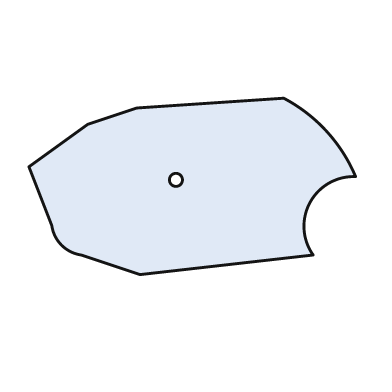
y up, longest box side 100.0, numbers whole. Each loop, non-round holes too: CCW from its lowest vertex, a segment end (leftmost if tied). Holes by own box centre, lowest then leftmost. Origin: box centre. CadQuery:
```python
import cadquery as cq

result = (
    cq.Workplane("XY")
    .moveTo(-16.0, -27.0)
    .lineTo(37.0, -21.0)
    .threePointArc((36.0, -5.0), (50.0, 3.0))
    .threePointArc((41.0, 17.0), (28.0, 27.0))
    .lineTo(-17.0, 24.0)
    .lineTo(-32.0, 19.0)
    .lineTo(-50.0, 6.0)
    .lineTo(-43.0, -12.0)
    .threePointArc((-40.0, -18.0), (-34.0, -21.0))
    .close()
    .moveTo(-5.0, 2.0)
    .circle(2.0)
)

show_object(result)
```